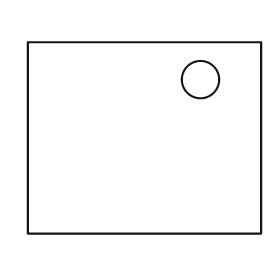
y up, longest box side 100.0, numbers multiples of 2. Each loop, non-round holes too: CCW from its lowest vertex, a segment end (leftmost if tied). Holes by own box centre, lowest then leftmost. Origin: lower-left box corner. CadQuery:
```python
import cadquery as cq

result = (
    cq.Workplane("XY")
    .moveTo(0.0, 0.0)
    .lineTo(100.0, 0.0)
    .lineTo(100.0, 82.0)
    .lineTo(0.0, 82.0)
    .close()
    .moveTo(74.0, 66.0)
    .circle(8.0)
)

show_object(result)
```